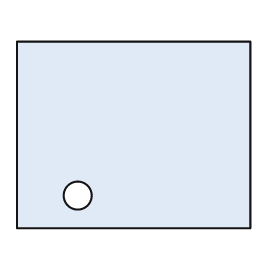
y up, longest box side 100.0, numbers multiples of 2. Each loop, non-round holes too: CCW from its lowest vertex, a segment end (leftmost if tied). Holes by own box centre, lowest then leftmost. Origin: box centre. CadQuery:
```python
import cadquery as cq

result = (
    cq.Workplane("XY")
    .moveTo(-50.0, -40.0)
    .lineTo(50.0, -40.0)
    .lineTo(50.0, 40.0)
    .lineTo(-50.0, 40.0)
    .close()
    .moveTo(-24.0, -26.0)
    .circle(6.0)
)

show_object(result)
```